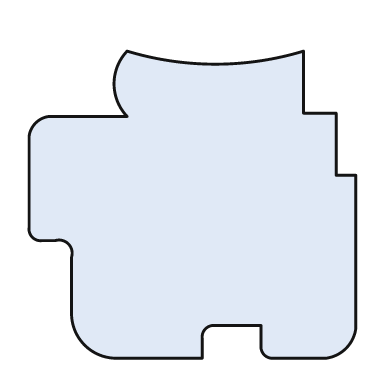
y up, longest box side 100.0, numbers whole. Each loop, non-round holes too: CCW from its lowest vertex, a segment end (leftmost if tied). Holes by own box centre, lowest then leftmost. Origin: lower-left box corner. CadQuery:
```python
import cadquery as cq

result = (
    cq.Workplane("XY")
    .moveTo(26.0, 0.0)
    .lineTo(53.0, 0.0)
    .lineTo(53.0, 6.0)
    .threePointArc((54.0, 9.0), (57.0, 10.0))
    .lineTo(71.0, 10.0)
    .lineTo(71.0, 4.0)
    .threePointArc((72.0, 1.0), (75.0, 0.0))
    .lineTo(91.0, 0.0)
    .threePointArc((97.0, 3.0), (100.0, 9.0))
    .lineTo(100.0, 56.0)
    .lineTo(94.0, 56.0)
    .lineTo(94.0, 75.0)
    .lineTo(84.0, 75.0)
    .lineTo(84.0, 94.0)
    .threePointArc((57.0, 90.0), (30.0, 94.0))
    .threePointArc((26.0, 84.0), (30.0, 74.0))
    .lineTo(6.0, 74.0)
    .threePointArc((2.0, 72.0), (0.0, 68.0))
    .lineTo(0.0, 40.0)
    .threePointArc((1.0, 37.0), (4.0, 36.0))
    .lineTo(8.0, 36.0)
    .threePointArc((12.0, 35.0), (13.0, 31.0))
    .lineTo(13.0, 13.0)
    .threePointArc((17.0, 4.0), (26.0, 0.0))
    .close()
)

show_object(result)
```